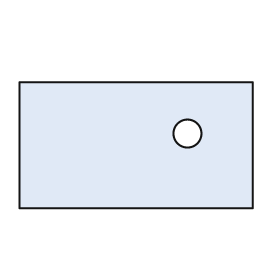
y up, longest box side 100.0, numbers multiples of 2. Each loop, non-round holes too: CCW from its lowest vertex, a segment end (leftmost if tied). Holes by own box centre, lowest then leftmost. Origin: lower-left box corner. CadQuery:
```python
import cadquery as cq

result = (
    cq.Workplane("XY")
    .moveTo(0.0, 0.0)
    .lineTo(100.0, 0.0)
    .lineTo(100.0, 54.0)
    .lineTo(0.0, 54.0)
    .close()
    .moveTo(72.0, 32.0)
    .circle(6.0)
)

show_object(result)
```